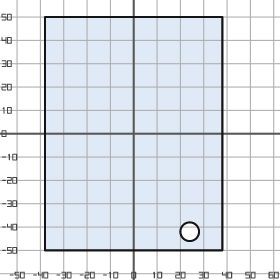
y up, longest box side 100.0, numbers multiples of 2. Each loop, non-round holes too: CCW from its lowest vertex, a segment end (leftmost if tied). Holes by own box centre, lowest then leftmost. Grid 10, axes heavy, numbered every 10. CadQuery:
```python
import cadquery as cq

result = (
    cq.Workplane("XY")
    .moveTo(-38.0, -50.0)
    .lineTo(38.0, -50.0)
    .lineTo(38.0, 50.0)
    .lineTo(-38.0, 50.0)
    .close()
    .moveTo(24.0, -42.0)
    .circle(4.0)
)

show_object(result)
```